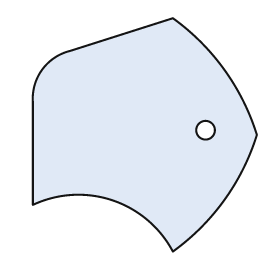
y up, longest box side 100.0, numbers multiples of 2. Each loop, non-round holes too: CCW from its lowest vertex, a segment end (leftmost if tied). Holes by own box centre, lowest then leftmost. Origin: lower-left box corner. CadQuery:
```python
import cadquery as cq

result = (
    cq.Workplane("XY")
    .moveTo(60.0, 0.0)
    .threePointArc((82.0, 22.0), (96.0, 50.0))
    .threePointArc((82.0, 78.0), (60.0, 100.0))
    .lineTo(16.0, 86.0)
    .threePointArc((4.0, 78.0), (0.0, 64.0))
    .lineTo(0.0, 20.0)
    .threePointArc((34.0, 22.0), (60.0, 0.0))
    .close()
    .moveTo(74.0, 52.0)
    .circle(4.0)
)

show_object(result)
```